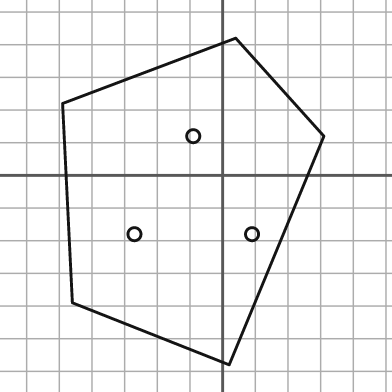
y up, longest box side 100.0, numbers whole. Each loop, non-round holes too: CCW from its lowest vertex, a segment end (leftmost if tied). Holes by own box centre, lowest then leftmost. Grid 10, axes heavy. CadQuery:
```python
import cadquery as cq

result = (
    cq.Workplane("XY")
    .moveTo(2.0, -58.0)
    .lineTo(31.0, 12.0)
    .lineTo(4.0, 42.0)
    .lineTo(-49.0, 22.0)
    .lineTo(-46.0, -39.0)
    .close()
    .moveTo(-27.0, -18.0)
    .circle(2.0)
    .moveTo(9.0, -18.0)
    .circle(2.0)
    .moveTo(-9.0, 12.0)
    .circle(2.0)
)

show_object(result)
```